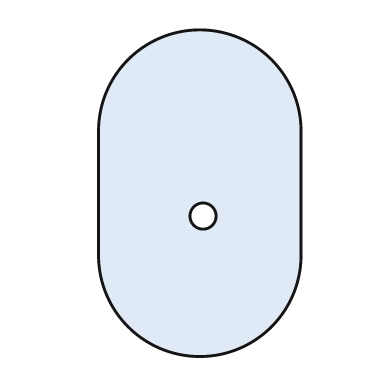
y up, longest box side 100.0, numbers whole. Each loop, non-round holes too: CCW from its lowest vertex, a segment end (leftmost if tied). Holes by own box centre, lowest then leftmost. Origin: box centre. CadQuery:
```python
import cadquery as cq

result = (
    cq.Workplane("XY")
    .moveTo(-31.0, -19.0)
    .threePointArc((0.0, -50.0), (31.0, -19.0))
    .lineTo(31.0, 19.0)
    .threePointArc((0.0, 50.0), (-31.0, 19.0))
    .close()
    .moveTo(1.0, -7.0)
    .circle(4.0)
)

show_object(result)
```